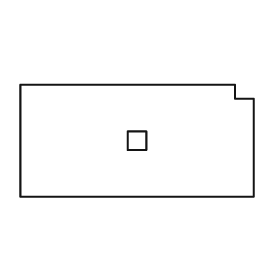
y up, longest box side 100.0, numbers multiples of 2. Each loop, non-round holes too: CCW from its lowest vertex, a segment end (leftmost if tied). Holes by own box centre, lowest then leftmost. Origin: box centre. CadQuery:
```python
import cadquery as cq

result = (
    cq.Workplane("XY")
    .moveTo(-50.0, -24.0)
    .lineTo(50.0, -24.0)
    .lineTo(50.0, 18.0)
    .lineTo(42.0, 18.0)
    .lineTo(42.0, 24.0)
    .lineTo(-50.0, 24.0)
    .close()
    .moveTo(-4.0, -4.0)
    .lineTo(4.0, -4.0)
    .lineTo(4.0, 4.0)
    .lineTo(-4.0, 4.0)
    .close()
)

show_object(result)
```